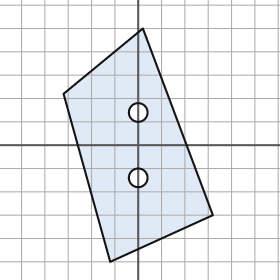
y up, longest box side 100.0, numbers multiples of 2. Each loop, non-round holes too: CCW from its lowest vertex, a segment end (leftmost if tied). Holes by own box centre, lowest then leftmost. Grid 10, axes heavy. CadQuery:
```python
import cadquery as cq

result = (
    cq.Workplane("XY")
    .moveTo(-12.0, -50.0)
    .lineTo(32.0, -30.0)
    .lineTo(2.0, 50.0)
    .lineTo(-32.0, 22.0)
    .close()
    .moveTo(0.0, -14.0)
    .circle(4.0)
    .moveTo(0.0, 14.0)
    .circle(4.0)
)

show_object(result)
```